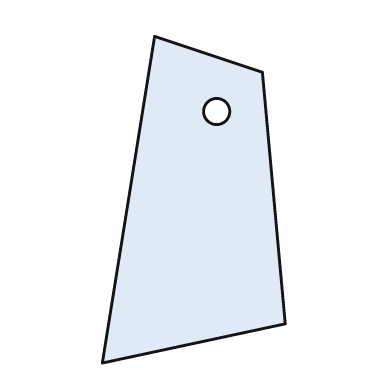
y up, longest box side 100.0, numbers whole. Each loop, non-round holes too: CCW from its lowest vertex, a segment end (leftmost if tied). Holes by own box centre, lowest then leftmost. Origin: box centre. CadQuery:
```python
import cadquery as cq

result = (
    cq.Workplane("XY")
    .moveTo(-28.0, -50.0)
    .lineTo(28.0, -38.0)
    .lineTo(21.0, 39.0)
    .lineTo(-12.0, 50.0)
    .close()
    .moveTo(7.0, 27.0)
    .circle(4.0)
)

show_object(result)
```